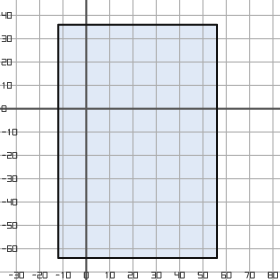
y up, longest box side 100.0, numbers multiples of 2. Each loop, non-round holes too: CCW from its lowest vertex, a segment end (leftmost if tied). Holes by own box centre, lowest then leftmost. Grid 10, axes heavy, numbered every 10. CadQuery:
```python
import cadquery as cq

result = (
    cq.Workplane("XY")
    .moveTo(-12.0, -64.0)
    .lineTo(56.0, -64.0)
    .lineTo(56.0, 36.0)
    .lineTo(-12.0, 36.0)
    .close()
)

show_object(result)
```